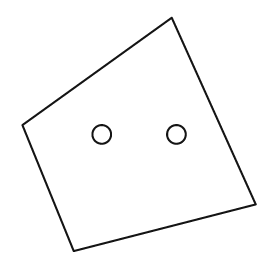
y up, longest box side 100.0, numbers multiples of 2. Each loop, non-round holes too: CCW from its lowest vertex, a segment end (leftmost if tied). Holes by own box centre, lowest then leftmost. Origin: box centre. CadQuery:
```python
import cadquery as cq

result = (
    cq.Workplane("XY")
    .moveTo(-28.0, -50.0)
    .lineTo(50.0, -30.0)
    .lineTo(14.0, 50.0)
    .lineTo(-50.0, 4.0)
    .close()
    .moveTo(-16.0, 0.0)
    .circle(4.0)
    .moveTo(16.0, 0.0)
    .circle(4.0)
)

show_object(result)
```